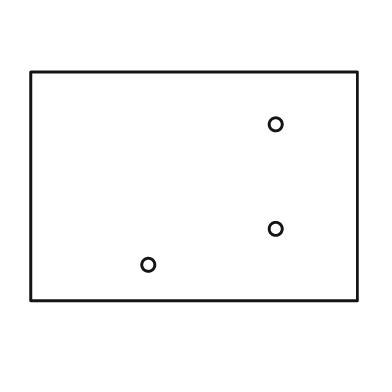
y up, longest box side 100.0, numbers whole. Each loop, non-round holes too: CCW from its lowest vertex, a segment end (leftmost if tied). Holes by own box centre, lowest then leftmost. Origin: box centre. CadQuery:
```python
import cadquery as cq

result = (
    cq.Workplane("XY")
    .moveTo(-50.0, -35.0)
    .lineTo(50.0, -35.0)
    .lineTo(50.0, 35.0)
    .lineTo(-50.0, 35.0)
    .close()
    .moveTo(-14.0, -24.0)
    .circle(2.0)
    .moveTo(25.0, -13.0)
    .circle(2.0)
    .moveTo(25.0, 19.0)
    .circle(2.0)
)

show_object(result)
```